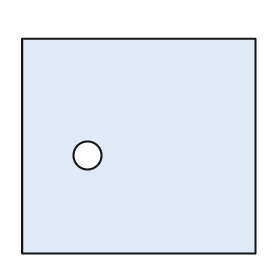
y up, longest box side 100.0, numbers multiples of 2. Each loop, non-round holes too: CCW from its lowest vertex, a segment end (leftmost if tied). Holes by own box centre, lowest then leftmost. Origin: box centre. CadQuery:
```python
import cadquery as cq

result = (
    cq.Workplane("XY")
    .moveTo(-50.0, -46.0)
    .lineTo(50.0, -46.0)
    .lineTo(50.0, 46.0)
    .lineTo(-50.0, 46.0)
    .close()
    .moveTo(-22.0, -4.0)
    .circle(6.0)
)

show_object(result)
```